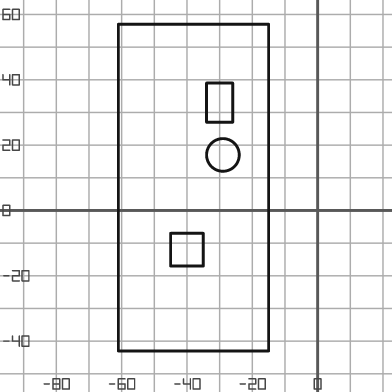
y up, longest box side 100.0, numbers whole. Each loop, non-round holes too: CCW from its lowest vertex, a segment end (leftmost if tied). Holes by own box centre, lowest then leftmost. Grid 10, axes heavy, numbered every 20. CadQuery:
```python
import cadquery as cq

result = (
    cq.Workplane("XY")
    .moveTo(-61.0, -43.0)
    .lineTo(-15.0, -43.0)
    .lineTo(-15.0, 57.0)
    .lineTo(-61.0, 57.0)
    .close()
    .moveTo(-45.0, -17.0)
    .lineTo(-35.0, -17.0)
    .lineTo(-35.0, -7.0)
    .lineTo(-45.0, -7.0)
    .close()
    .moveTo(-29.0, 17.0)
    .circle(5.0)
    .moveTo(-34.0, 27.0)
    .lineTo(-26.0, 27.0)
    .lineTo(-26.0, 39.0)
    .lineTo(-34.0, 39.0)
    .close()
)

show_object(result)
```